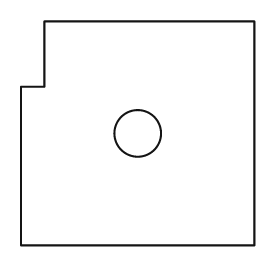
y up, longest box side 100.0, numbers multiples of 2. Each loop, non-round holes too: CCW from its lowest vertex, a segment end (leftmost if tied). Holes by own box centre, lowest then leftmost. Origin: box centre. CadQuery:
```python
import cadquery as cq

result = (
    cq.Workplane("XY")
    .moveTo(-50.0, -48.0)
    .lineTo(50.0, -48.0)
    .lineTo(50.0, 48.0)
    .lineTo(-40.0, 48.0)
    .lineTo(-40.0, 20.0)
    .lineTo(-50.0, 20.0)
    .close()
    .moveTo(0.0, 0.0)
    .circle(10.0)
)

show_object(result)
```